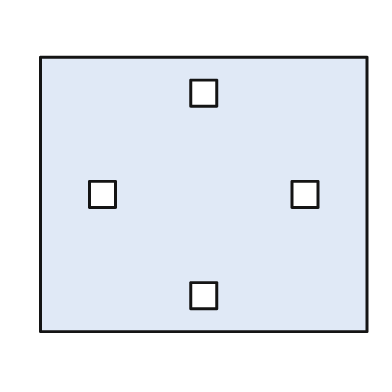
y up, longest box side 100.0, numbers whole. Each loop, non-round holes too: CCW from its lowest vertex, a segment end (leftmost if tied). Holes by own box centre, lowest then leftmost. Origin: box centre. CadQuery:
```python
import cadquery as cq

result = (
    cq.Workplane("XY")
    .moveTo(-50.0, -42.0)
    .lineTo(50.0, -42.0)
    .lineTo(50.0, 42.0)
    .lineTo(-50.0, 42.0)
    .close()
    .moveTo(-4.0, -35.0)
    .lineTo(4.0, -35.0)
    .lineTo(4.0, -27.0)
    .lineTo(-4.0, -27.0)
    .close()
    .moveTo(-35.0, -4.0)
    .lineTo(-27.0, -4.0)
    .lineTo(-27.0, 4.0)
    .lineTo(-35.0, 4.0)
    .close()
    .moveTo(27.0, -4.0)
    .lineTo(35.0, -4.0)
    .lineTo(35.0, 4.0)
    .lineTo(27.0, 4.0)
    .close()
    .moveTo(-4.0, 27.0)
    .lineTo(4.0, 27.0)
    .lineTo(4.0, 35.0)
    .lineTo(-4.0, 35.0)
    .close()
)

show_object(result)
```